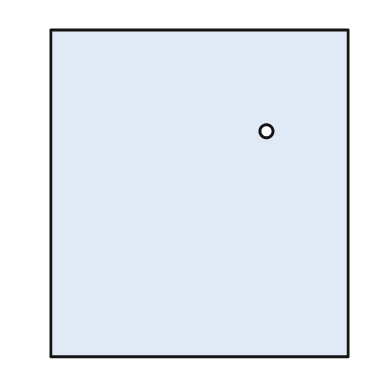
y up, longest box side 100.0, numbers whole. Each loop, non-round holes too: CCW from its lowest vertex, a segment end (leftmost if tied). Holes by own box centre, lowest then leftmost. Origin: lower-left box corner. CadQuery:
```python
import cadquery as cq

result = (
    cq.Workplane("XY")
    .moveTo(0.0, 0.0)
    .lineTo(91.0, 0.0)
    .lineTo(91.0, 100.0)
    .lineTo(0.0, 100.0)
    .close()
    .moveTo(66.0, 69.0)
    .circle(2.0)
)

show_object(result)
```